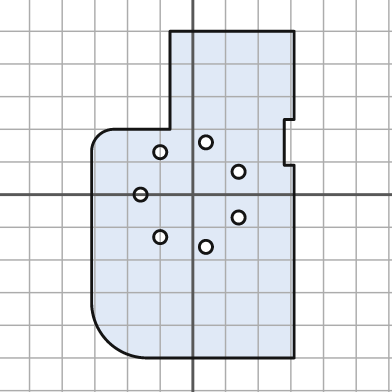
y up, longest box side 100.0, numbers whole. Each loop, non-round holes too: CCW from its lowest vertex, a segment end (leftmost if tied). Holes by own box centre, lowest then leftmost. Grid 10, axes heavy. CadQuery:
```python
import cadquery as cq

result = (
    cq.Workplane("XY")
    .moveTo(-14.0, -50.0)
    .lineTo(31.0, -50.0)
    .lineTo(31.0, 9.0)
    .lineTo(28.0, 9.0)
    .lineTo(28.0, 23.0)
    .lineTo(31.0, 23.0)
    .lineTo(31.0, 50.0)
    .lineTo(-7.0, 50.0)
    .lineTo(-7.0, 20.0)
    .lineTo(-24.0, 20.0)
    .threePointArc((-29.0, 18.0), (-31.0, 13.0))
    .lineTo(-31.0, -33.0)
    .threePointArc((-26.0, -45.0), (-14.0, -50.0))
    .close()
    .moveTo(4.0, -16.0)
    .circle(2.0)
    .moveTo(-10.0, -13.0)
    .circle(2.0)
    .moveTo(14.0, -7.0)
    .circle(2.0)
    .moveTo(-16.0, 0.0)
    .circle(2.0)
    .moveTo(14.0, 7.0)
    .circle(2.0)
    .moveTo(-10.0, 13.0)
    .circle(2.0)
    .moveTo(4.0, 16.0)
    .circle(2.0)
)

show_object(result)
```